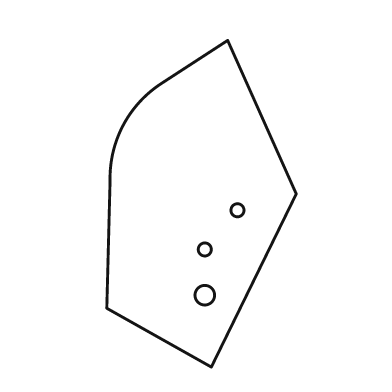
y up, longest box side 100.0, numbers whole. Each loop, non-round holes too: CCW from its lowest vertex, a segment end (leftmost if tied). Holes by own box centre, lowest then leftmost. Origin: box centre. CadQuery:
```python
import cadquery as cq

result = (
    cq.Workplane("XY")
    .moveTo(3.0, -50.0)
    .lineTo(29.0, 3.0)
    .lineTo(8.0, 50.0)
    .lineTo(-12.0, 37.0)
    .threePointArc((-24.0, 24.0), (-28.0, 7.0))
    .lineTo(-29.0, -32.0)
    .close()
    .moveTo(1.0, -28.0)
    .circle(3.0)
    .moveTo(1.0, -14.0)
    .circle(2.0)
    .moveTo(11.0, -2.0)
    .circle(2.0)
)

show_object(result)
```